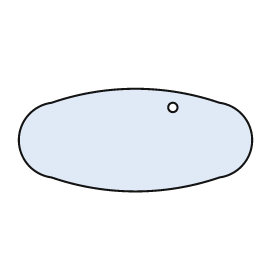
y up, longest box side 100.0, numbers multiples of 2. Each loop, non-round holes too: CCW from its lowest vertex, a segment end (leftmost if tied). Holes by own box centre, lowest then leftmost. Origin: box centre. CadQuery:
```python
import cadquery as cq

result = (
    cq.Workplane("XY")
    .moveTo(-36.0, -16.0)
    .threePointArc((0.0, -22.0), (36.0, -16.0))
    .threePointArc((50.0, 0.0), (36.0, 16.0))
    .threePointArc((0.0, 22.0), (-36.0, 16.0))
    .threePointArc((-50.0, 0.0), (-36.0, -16.0))
    .close()
    .moveTo(16.0, 14.0)
    .circle(2.0)
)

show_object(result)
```